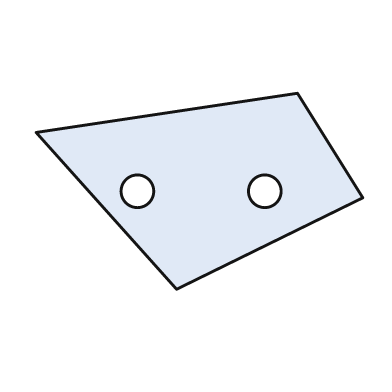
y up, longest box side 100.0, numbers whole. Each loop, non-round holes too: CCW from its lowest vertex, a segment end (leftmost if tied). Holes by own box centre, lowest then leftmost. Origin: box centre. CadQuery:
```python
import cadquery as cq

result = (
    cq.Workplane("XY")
    .moveTo(-7.0, -30.0)
    .lineTo(50.0, -2.0)
    .lineTo(30.0, 30.0)
    .lineTo(-50.0, 18.0)
    .close()
    .moveTo(-19.0, 0.0)
    .circle(5.0)
    .moveTo(20.0, 0.0)
    .circle(5.0)
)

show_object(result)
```